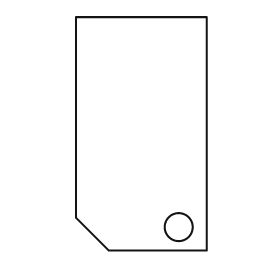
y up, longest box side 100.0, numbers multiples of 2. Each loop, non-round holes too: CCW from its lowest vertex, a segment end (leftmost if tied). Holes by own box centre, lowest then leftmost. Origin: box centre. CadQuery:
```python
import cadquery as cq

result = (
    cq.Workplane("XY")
    .moveTo(-14.0, -50.0)
    .lineTo(28.0, -50.0)
    .lineTo(28.0, 50.0)
    .lineTo(-28.0, 50.0)
    .lineTo(-28.0, -36.0)
    .close()
    .moveTo(16.0, -40.0)
    .circle(6.0)
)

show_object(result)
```